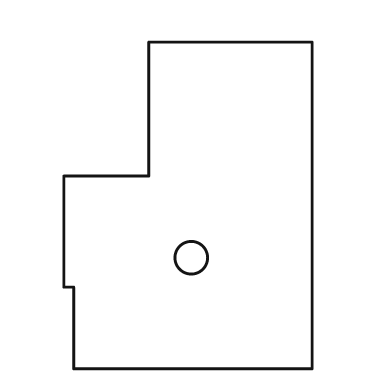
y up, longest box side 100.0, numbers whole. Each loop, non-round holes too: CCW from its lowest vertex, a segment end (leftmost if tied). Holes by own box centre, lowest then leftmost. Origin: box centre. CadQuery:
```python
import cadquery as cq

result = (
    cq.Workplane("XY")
    .moveTo(-35.0, -50.0)
    .lineTo(38.0, -50.0)
    .lineTo(38.0, 50.0)
    .lineTo(-12.0, 50.0)
    .lineTo(-12.0, 9.0)
    .lineTo(-38.0, 9.0)
    .lineTo(-38.0, -25.0)
    .lineTo(-35.0, -25.0)
    .close()
    .moveTo(1.0, -16.0)
    .circle(5.0)
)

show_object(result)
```